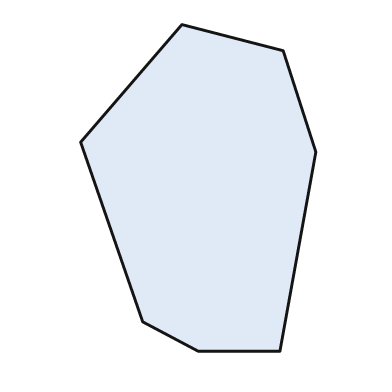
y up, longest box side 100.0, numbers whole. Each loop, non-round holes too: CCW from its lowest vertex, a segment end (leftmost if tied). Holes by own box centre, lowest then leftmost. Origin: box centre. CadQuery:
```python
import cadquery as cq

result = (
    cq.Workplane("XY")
    .moveTo(0.0, -50.0)
    .lineTo(25.0, -50.0)
    .lineTo(36.0, 11.0)
    .lineTo(26.0, 42.0)
    .lineTo(-5.0, 50.0)
    .lineTo(-36.0, 14.0)
    .lineTo(-17.0, -41.0)
    .close()
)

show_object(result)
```